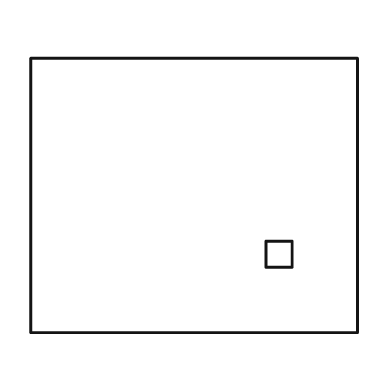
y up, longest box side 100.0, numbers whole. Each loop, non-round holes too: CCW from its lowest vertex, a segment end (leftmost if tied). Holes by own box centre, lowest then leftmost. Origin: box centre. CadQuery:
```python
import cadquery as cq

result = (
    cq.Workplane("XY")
    .moveTo(-50.0, -42.0)
    .lineTo(50.0, -42.0)
    .lineTo(50.0, 42.0)
    .lineTo(-50.0, 42.0)
    .close()
    .moveTo(22.0, -22.0)
    .lineTo(30.0, -22.0)
    .lineTo(30.0, -14.0)
    .lineTo(22.0, -14.0)
    .close()
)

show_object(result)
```